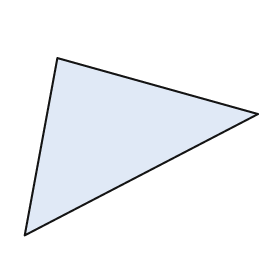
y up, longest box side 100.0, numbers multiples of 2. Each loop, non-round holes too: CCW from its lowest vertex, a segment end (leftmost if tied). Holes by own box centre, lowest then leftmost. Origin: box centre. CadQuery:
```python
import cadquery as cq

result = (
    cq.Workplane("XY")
    .moveTo(-50.0, -38.0)
    .lineTo(50.0, 14.0)
    .lineTo(-36.0, 38.0)
    .close()
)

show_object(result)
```